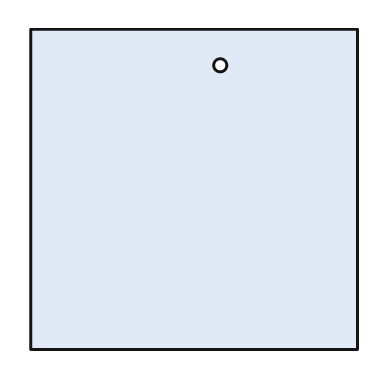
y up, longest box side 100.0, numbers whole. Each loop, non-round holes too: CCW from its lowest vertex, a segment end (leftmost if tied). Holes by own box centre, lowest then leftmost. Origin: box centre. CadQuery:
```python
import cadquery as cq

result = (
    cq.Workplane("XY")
    .moveTo(-50.0, -49.0)
    .lineTo(50.0, -49.0)
    .lineTo(50.0, 49.0)
    .lineTo(-50.0, 49.0)
    .close()
    .moveTo(8.0, 38.0)
    .circle(2.0)
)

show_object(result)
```